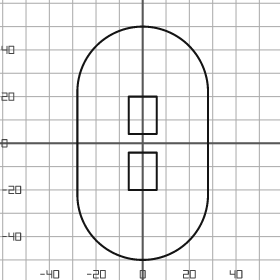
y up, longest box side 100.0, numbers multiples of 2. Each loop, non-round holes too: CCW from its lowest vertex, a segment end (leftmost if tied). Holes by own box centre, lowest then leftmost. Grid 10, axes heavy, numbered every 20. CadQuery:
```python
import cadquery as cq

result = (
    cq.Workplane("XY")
    .moveTo(-28.0, -22.0)
    .threePointArc((0.0, -50.0), (28.0, -22.0))
    .lineTo(28.0, 22.0)
    .threePointArc((0.0, 50.0), (-28.0, 22.0))
    .close()
    .moveTo(-6.0, -20.0)
    .lineTo(6.0, -20.0)
    .lineTo(6.0, -4.0)
    .lineTo(-6.0, -4.0)
    .close()
    .moveTo(-6.0, 4.0)
    .lineTo(6.0, 4.0)
    .lineTo(6.0, 20.0)
    .lineTo(-6.0, 20.0)
    .close()
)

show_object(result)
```